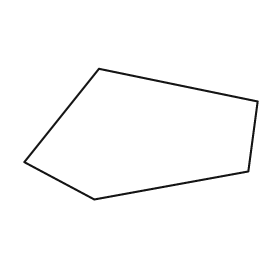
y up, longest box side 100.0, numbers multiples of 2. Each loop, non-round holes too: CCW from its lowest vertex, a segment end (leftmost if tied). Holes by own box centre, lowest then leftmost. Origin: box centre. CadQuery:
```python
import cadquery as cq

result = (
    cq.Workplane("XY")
    .moveTo(-20.0, -28.0)
    .lineTo(46.0, -16.0)
    .lineTo(50.0, 14.0)
    .lineTo(-18.0, 28.0)
    .lineTo(-50.0, -12.0)
    .close()
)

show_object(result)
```